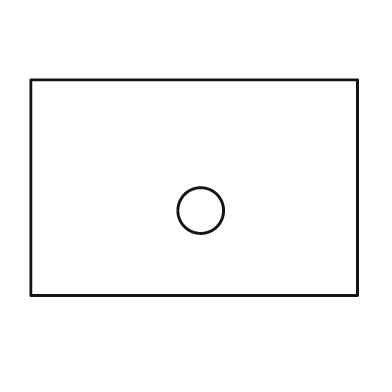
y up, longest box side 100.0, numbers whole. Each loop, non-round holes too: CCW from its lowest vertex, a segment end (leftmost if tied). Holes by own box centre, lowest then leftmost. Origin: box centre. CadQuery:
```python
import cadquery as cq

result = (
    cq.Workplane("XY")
    .moveTo(-50.0, -33.0)
    .lineTo(50.0, -33.0)
    .lineTo(50.0, 33.0)
    .lineTo(-50.0, 33.0)
    .close()
    .moveTo(2.0, -7.0)
    .circle(7.0)
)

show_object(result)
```